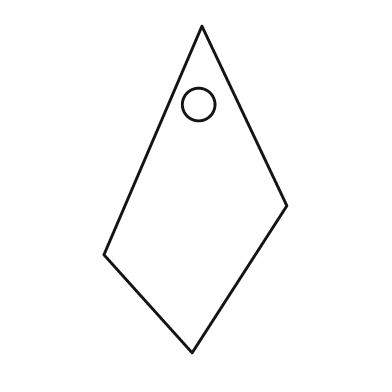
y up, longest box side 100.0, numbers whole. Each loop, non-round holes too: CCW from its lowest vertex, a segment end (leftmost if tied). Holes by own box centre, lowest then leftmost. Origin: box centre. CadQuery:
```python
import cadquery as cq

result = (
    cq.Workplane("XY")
    .moveTo(-1.0, -50.0)
    .lineTo(28.0, -5.0)
    .lineTo(2.0, 50.0)
    .lineTo(-28.0, -20.0)
    .close()
    .moveTo(1.0, 26.0)
    .circle(5.0)
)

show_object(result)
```